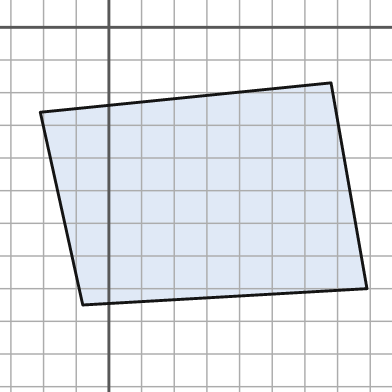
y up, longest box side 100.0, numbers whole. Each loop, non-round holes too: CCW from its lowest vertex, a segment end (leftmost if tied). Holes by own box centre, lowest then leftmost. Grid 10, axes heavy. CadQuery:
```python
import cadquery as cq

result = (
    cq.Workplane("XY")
    .moveTo(-8.0, -85.0)
    .lineTo(79.0, -80.0)
    .lineTo(68.0, -17.0)
    .lineTo(-21.0, -26.0)
    .close()
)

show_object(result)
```